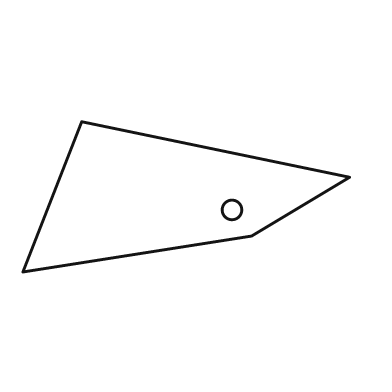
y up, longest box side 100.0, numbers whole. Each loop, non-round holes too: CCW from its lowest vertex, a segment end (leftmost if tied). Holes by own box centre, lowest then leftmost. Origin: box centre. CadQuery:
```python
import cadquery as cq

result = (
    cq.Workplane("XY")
    .moveTo(-50.0, -23.0)
    .lineTo(20.0, -12.0)
    .lineTo(50.0, 6.0)
    .lineTo(-32.0, 23.0)
    .close()
    .moveTo(14.0, -4.0)
    .circle(3.0)
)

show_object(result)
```